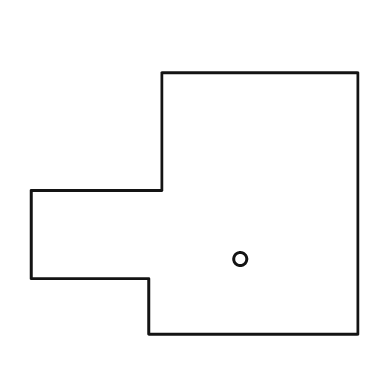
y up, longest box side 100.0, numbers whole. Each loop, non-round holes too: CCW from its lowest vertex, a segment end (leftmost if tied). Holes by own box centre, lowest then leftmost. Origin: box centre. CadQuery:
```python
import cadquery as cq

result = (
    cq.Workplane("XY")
    .moveTo(-14.0, -40.0)
    .lineTo(50.0, -40.0)
    .lineTo(50.0, 40.0)
    .lineTo(-10.0, 40.0)
    .lineTo(-10.0, 4.0)
    .lineTo(-50.0, 4.0)
    .lineTo(-50.0, -23.0)
    .lineTo(-14.0, -23.0)
    .close()
    .moveTo(14.0, -17.0)
    .circle(2.0)
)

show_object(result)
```